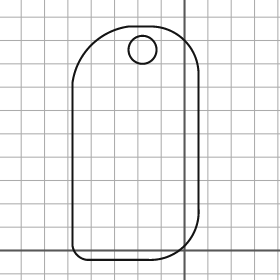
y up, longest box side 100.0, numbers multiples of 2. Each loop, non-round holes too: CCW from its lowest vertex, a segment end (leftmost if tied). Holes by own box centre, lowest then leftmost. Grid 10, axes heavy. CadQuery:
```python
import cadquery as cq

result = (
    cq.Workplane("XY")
    .moveTo(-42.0, -4.0)
    .lineTo(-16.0, -4.0)
    .threePointArc((0.0, 2.0), (6.0, 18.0))
    .lineTo(6.0, 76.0)
    .threePointArc((0.0, 90.0), (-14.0, 96.0))
    .lineTo(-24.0, 96.0)
    .threePointArc((-40.0, 88.0), (-48.0, 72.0))
    .lineTo(-48.0, 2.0)
    .threePointArc((-46.0, -2.0), (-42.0, -4.0))
    .close()
    .moveTo(-18.0, 86.0)
    .circle(6.0)
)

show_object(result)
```